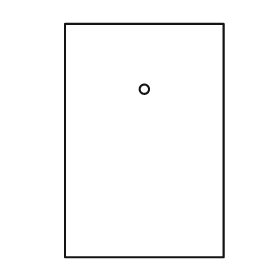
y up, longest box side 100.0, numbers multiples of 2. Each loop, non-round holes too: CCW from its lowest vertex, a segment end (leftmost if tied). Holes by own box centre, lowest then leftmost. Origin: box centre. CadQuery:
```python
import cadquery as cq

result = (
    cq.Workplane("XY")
    .moveTo(-34.0, -50.0)
    .lineTo(34.0, -50.0)
    .lineTo(34.0, 50.0)
    .lineTo(-34.0, 50.0)
    .close()
    .moveTo(0.0, 22.0)
    .circle(2.0)
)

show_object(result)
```